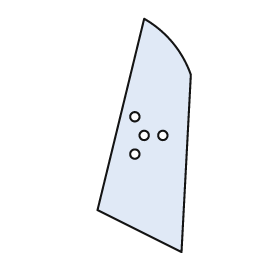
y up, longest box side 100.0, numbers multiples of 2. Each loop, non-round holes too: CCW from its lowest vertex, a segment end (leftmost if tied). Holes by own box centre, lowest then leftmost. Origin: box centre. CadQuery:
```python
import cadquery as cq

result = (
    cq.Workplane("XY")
    .moveTo(16.0, -50.0)
    .lineTo(20.0, 26.0)
    .threePointArc((12.0, 40.0), (0.0, 50.0))
    .lineTo(-20.0, -32.0)
    .close()
    .moveTo(-4.0, -8.0)
    .circle(2.0)
    .moveTo(0.0, 0.0)
    .circle(2.0)
    .moveTo(8.0, 0.0)
    .circle(2.0)
    .moveTo(-4.0, 8.0)
    .circle(2.0)
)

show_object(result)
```